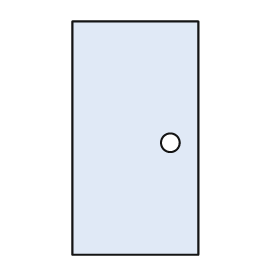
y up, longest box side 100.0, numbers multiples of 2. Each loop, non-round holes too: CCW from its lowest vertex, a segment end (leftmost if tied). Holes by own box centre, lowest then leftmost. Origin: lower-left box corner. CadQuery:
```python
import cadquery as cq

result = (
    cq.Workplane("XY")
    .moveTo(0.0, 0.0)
    .lineTo(54.0, 0.0)
    .lineTo(54.0, 100.0)
    .lineTo(0.0, 100.0)
    .close()
    .moveTo(42.0, 48.0)
    .circle(4.0)
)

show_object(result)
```